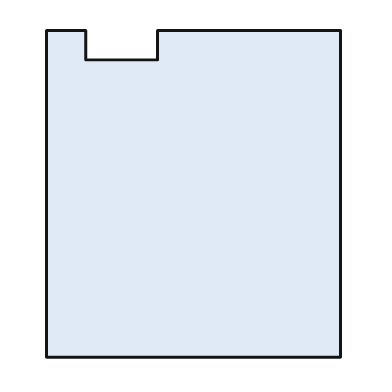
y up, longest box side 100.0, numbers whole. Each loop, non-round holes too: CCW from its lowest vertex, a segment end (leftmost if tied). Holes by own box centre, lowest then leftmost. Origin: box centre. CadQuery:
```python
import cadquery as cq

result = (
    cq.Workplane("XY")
    .moveTo(-45.0, -50.0)
    .lineTo(45.0, -50.0)
    .lineTo(45.0, 50.0)
    .lineTo(-11.0, 50.0)
    .lineTo(-11.0, 41.0)
    .lineTo(-33.0, 41.0)
    .lineTo(-33.0, 50.0)
    .lineTo(-45.0, 50.0)
    .close()
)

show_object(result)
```